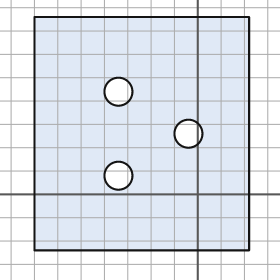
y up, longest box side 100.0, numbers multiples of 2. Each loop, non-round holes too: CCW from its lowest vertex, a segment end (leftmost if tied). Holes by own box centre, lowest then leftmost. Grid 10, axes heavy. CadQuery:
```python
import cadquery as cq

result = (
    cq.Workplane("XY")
    .moveTo(-70.0, -24.0)
    .lineTo(22.0, -24.0)
    .lineTo(22.0, 76.0)
    .lineTo(-70.0, 76.0)
    .close()
    .moveTo(-34.0, 8.0)
    .circle(6.0)
    .moveTo(-4.0, 26.0)
    .circle(6.0)
    .moveTo(-34.0, 44.0)
    .circle(6.0)
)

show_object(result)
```